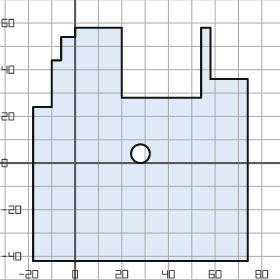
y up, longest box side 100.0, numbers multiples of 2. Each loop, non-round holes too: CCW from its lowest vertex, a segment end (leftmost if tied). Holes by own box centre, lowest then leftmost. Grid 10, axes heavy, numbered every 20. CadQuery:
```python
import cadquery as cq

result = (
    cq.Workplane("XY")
    .moveTo(-18.0, -42.0)
    .lineTo(74.0, -42.0)
    .lineTo(74.0, 36.0)
    .lineTo(58.0, 36.0)
    .lineTo(58.0, 58.0)
    .lineTo(54.0, 58.0)
    .lineTo(54.0, 28.0)
    .lineTo(20.0, 28.0)
    .lineTo(20.0, 58.0)
    .lineTo(0.0, 58.0)
    .lineTo(0.0, 54.0)
    .lineTo(-6.0, 54.0)
    .lineTo(-6.0, 44.0)
    .lineTo(-10.0, 44.0)
    .lineTo(-10.0, 24.0)
    .lineTo(-18.0, 24.0)
    .close()
    .moveTo(28.0, 4.0)
    .circle(4.0)
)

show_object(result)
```